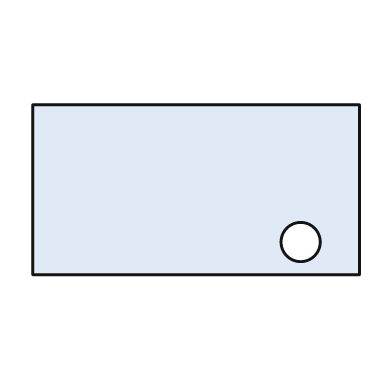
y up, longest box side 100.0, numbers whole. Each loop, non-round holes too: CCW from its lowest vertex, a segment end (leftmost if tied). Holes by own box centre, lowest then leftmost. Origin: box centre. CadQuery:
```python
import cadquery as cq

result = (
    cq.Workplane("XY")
    .moveTo(-50.0, -26.0)
    .lineTo(50.0, -26.0)
    .lineTo(50.0, 26.0)
    .lineTo(-50.0, 26.0)
    .close()
    .moveTo(32.0, -16.0)
    .circle(6.0)
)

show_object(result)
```